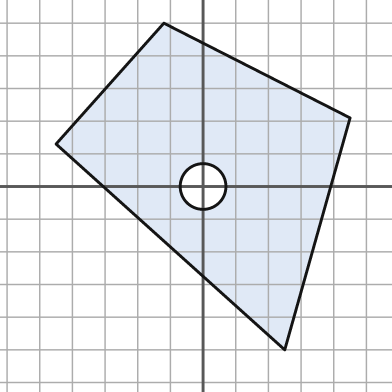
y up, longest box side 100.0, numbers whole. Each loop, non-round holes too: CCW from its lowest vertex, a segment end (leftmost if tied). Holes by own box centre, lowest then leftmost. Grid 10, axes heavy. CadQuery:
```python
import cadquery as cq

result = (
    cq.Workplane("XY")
    .moveTo(25.0, -50.0)
    .lineTo(45.0, 21.0)
    .lineTo(-12.0, 50.0)
    .lineTo(-45.0, 13.0)
    .close()
    .moveTo(0.0, 0.0)
    .circle(7.0)
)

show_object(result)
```